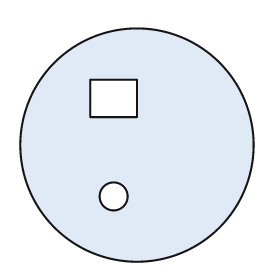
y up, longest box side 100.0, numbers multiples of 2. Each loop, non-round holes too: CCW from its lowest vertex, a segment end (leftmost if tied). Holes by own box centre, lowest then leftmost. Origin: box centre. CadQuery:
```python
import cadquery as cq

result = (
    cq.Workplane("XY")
    .moveTo(0.0, 0.0)
    .circle(50.0)
    .moveTo(-10.0, -22.0)
    .circle(6.0)
    .moveTo(-20.0, 12.0)
    .lineTo(0.0, 12.0)
    .lineTo(0.0, 28.0)
    .lineTo(-20.0, 28.0)
    .close()
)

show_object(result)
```